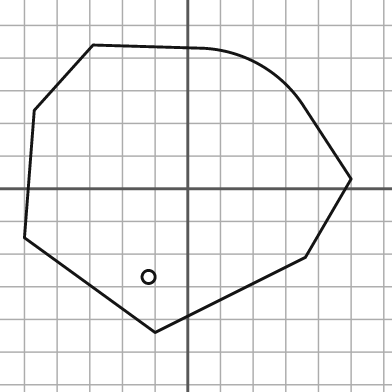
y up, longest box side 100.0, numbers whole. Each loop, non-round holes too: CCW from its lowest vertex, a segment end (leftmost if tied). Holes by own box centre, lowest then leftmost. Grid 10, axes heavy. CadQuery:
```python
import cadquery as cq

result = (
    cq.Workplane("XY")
    .moveTo(-10.0, -44.0)
    .lineTo(36.0, -21.0)
    .lineTo(50.0, 3.0)
    .lineTo(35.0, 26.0)
    .threePointArc((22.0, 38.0), (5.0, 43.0))
    .lineTo(-29.0, 44.0)
    .lineTo(-47.0, 24.0)
    .lineTo(-50.0, -15.0)
    .close()
    .moveTo(-12.0, -27.0)
    .circle(2.0)
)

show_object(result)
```